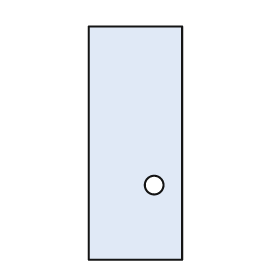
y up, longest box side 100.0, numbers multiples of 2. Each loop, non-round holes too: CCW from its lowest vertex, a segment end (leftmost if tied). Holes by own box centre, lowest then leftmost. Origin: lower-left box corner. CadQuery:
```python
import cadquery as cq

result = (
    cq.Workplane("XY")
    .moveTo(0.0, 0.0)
    .lineTo(40.0, 0.0)
    .lineTo(40.0, 100.0)
    .lineTo(0.0, 100.0)
    .close()
    .moveTo(28.0, 32.0)
    .circle(4.0)
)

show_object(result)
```